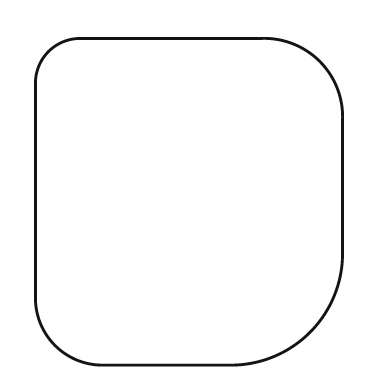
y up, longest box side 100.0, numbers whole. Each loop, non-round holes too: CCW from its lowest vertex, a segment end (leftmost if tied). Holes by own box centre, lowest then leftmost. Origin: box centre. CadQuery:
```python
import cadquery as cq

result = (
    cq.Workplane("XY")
    .moveTo(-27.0, -50.0)
    .lineTo(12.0, -50.0)
    .threePointArc((37.0, -40.0), (47.0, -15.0))
    .lineTo(47.0, 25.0)
    .threePointArc((40.0, 43.0), (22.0, 50.0))
    .lineTo(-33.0, 50.0)
    .threePointArc((-43.0, 46.0), (-47.0, 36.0))
    .lineTo(-47.0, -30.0)
    .threePointArc((-41.0, -44.0), (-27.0, -50.0))
    .close()
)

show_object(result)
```